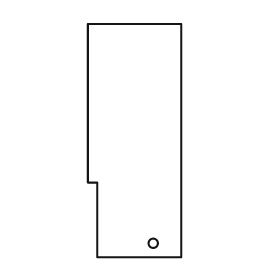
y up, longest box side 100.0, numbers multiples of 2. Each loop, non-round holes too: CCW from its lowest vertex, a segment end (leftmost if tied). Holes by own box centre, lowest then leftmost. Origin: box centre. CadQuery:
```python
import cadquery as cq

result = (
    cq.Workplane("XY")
    .moveTo(-16.0, -50.0)
    .lineTo(20.0, -50.0)
    .lineTo(20.0, 50.0)
    .lineTo(-20.0, 50.0)
    .lineTo(-20.0, -18.0)
    .lineTo(-16.0, -18.0)
    .close()
    .moveTo(8.0, -44.0)
    .circle(2.0)
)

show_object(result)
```